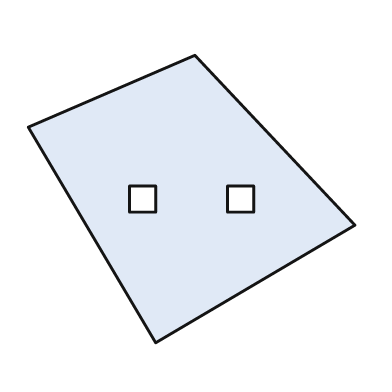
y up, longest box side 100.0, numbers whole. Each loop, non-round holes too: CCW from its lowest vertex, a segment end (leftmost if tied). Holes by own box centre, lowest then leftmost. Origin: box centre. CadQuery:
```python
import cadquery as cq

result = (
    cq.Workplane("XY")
    .moveTo(-11.0, -44.0)
    .lineTo(50.0, -8.0)
    .lineTo(1.0, 44.0)
    .lineTo(-50.0, 22.0)
    .close()
    .moveTo(-19.0, -4.0)
    .lineTo(-11.0, -4.0)
    .lineTo(-11.0, 4.0)
    .lineTo(-19.0, 4.0)
    .close()
    .moveTo(11.0, -4.0)
    .lineTo(19.0, -4.0)
    .lineTo(19.0, 4.0)
    .lineTo(11.0, 4.0)
    .close()
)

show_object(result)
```